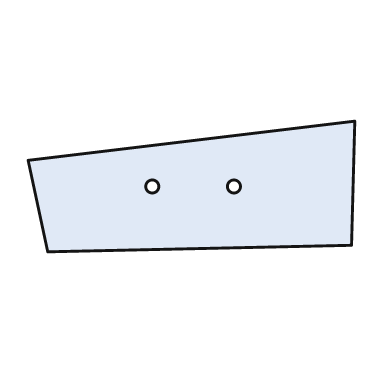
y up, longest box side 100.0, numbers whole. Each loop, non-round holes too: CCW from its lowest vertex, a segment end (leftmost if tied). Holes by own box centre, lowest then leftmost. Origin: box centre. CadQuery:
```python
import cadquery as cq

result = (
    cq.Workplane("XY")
    .moveTo(-44.0, -20.0)
    .lineTo(49.0, -18.0)
    .lineTo(50.0, 20.0)
    .lineTo(-50.0, 8.0)
    .close()
    .moveTo(-12.0, 0.0)
    .circle(2.0)
    .moveTo(13.0, 0.0)
    .circle(2.0)
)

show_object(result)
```